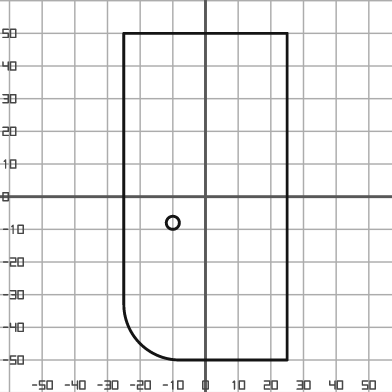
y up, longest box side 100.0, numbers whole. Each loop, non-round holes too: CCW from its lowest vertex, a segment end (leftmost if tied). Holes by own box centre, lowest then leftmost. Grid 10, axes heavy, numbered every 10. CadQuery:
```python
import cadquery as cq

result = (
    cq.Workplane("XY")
    .moveTo(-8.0, -50.0)
    .lineTo(25.0, -50.0)
    .lineTo(25.0, 50.0)
    .lineTo(-25.0, 50.0)
    .lineTo(-25.0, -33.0)
    .threePointArc((-20.0, -45.0), (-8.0, -50.0))
    .close()
    .moveTo(-10.0, -8.0)
    .circle(2.0)
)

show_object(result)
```